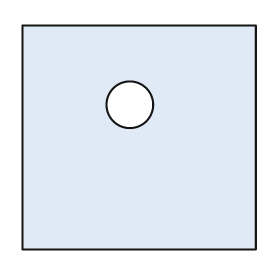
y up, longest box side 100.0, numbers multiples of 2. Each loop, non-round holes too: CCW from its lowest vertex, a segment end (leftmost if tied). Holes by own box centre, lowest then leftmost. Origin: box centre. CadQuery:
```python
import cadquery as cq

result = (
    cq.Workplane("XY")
    .moveTo(-50.0, -48.0)
    .lineTo(50.0, -48.0)
    .lineTo(50.0, 48.0)
    .lineTo(-50.0, 48.0)
    .close()
    .moveTo(-4.0, 14.0)
    .circle(10.0)
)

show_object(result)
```